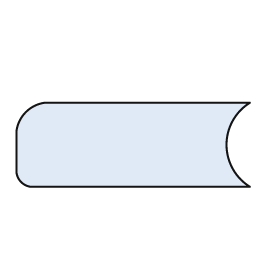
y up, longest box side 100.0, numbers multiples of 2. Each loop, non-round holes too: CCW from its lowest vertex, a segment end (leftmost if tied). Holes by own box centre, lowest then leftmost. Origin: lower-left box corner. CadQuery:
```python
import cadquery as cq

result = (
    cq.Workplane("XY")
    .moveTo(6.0, 0.0)
    .lineTo(100.0, 0.0)
    .threePointArc((90.0, 18.0), (100.0, 36.0))
    .lineTo(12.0, 36.0)
    .threePointArc((4.0, 32.0), (0.0, 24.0))
    .lineTo(0.0, 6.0)
    .threePointArc((2.0, 2.0), (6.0, 0.0))
    .close()
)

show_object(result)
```